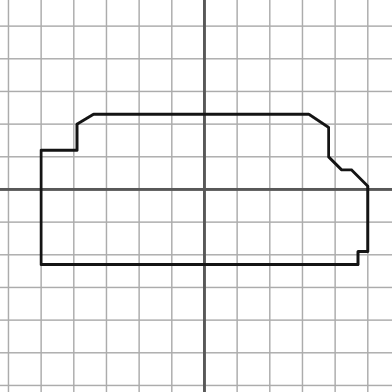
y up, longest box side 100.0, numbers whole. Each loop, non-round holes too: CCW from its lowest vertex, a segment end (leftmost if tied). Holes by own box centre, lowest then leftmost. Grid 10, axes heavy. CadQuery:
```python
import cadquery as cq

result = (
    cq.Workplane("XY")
    .moveTo(-50.0, -23.0)
    .lineTo(47.0, -23.0)
    .lineTo(47.0, -19.0)
    .lineTo(50.0, -19.0)
    .lineTo(50.0, 1.0)
    .lineTo(45.0, 6.0)
    .lineTo(42.0, 6.0)
    .lineTo(38.0, 10.0)
    .lineTo(38.0, 19.0)
    .lineTo(32.0, 23.0)
    .lineTo(-34.0, 23.0)
    .lineTo(-39.0, 20.0)
    .lineTo(-39.0, 12.0)
    .lineTo(-50.0, 12.0)
    .close()
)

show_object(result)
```